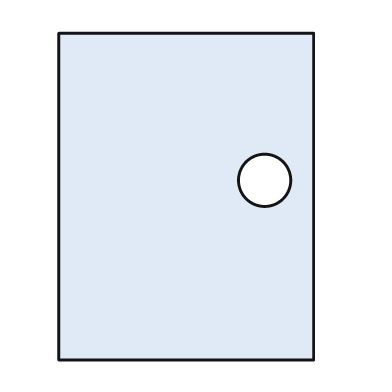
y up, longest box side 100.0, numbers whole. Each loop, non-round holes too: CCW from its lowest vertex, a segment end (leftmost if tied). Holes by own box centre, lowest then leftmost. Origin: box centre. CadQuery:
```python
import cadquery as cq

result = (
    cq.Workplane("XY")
    .moveTo(-39.0, -50.0)
    .lineTo(39.0, -50.0)
    .lineTo(39.0, 50.0)
    .lineTo(-39.0, 50.0)
    .close()
    .moveTo(24.0, 5.0)
    .circle(8.0)
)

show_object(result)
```